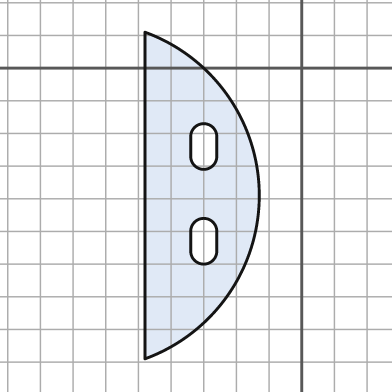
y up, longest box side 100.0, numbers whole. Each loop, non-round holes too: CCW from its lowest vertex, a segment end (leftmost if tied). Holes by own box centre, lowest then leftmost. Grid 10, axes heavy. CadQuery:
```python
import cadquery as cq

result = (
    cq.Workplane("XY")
    .moveTo(-48.0, -89.0)
    .threePointArc((-13.0, -39.0), (-48.0, 11.0))
    .close()
    .moveTo(-34.0, -56.0)
    .threePointArc((-30.0, -60.0), (-26.0, -56.0))
    .lineTo(-26.0, -50.0)
    .threePointArc((-30.0, -46.0), (-34.0, -50.0))
    .close()
    .moveTo(-34.0, -27.0)
    .threePointArc((-30.0, -31.0), (-26.0, -27.0))
    .lineTo(-26.0, -21.0)
    .threePointArc((-30.0, -17.0), (-34.0, -21.0))
    .close()
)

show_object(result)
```